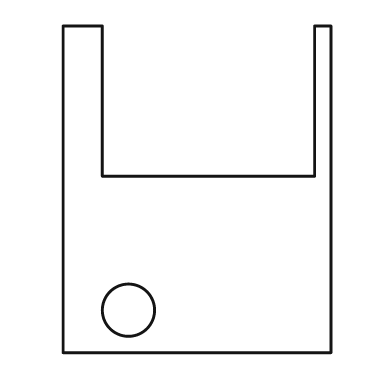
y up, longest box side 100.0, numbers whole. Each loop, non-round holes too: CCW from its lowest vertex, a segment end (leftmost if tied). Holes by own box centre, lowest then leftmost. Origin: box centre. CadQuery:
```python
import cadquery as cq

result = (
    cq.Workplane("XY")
    .moveTo(-41.0, -50.0)
    .lineTo(41.0, -50.0)
    .lineTo(41.0, 50.0)
    .lineTo(36.0, 50.0)
    .lineTo(36.0, 4.0)
    .lineTo(-29.0, 4.0)
    .lineTo(-29.0, 50.0)
    .lineTo(-41.0, 50.0)
    .close()
    .moveTo(-21.0, -37.0)
    .circle(8.0)
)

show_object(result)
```